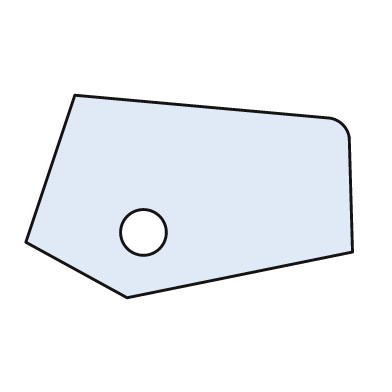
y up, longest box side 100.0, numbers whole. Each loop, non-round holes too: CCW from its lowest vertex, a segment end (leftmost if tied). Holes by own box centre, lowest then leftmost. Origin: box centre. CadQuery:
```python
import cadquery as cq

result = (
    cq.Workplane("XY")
    .moveTo(-19.0, -31.0)
    .lineTo(50.0, -17.0)
    .lineTo(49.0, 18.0)
    .threePointArc((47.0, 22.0), (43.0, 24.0))
    .lineTo(-35.0, 31.0)
    .lineTo(-50.0, -14.0)
    .close()
    .moveTo(-14.0, -11.0)
    .circle(7.0)
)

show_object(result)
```